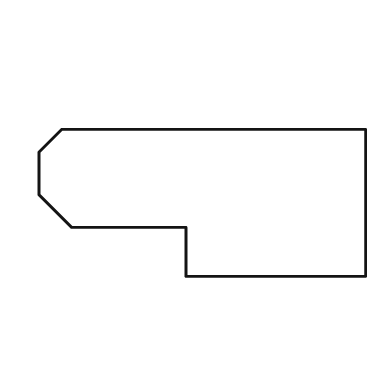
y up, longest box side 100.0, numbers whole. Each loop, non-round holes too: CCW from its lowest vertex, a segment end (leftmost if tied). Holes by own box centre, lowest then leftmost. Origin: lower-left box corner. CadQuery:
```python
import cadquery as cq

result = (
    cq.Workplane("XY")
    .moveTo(45.0, 0.0)
    .lineTo(100.0, 0.0)
    .lineTo(100.0, 45.0)
    .lineTo(7.0, 45.0)
    .lineTo(0.0, 38.0)
    .lineTo(0.0, 25.0)
    .lineTo(10.0, 15.0)
    .lineTo(45.0, 15.0)
    .close()
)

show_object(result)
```